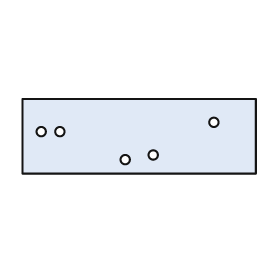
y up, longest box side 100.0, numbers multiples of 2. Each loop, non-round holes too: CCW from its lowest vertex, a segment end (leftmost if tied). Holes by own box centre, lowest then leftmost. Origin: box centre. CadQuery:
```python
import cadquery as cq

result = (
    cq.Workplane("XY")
    .moveTo(-50.0, -16.0)
    .lineTo(50.0, -16.0)
    .lineTo(50.0, 16.0)
    .lineTo(-50.0, 16.0)
    .close()
    .moveTo(-6.0, -10.0)
    .circle(2.0)
    .moveTo(6.0, -8.0)
    .circle(2.0)
    .moveTo(-42.0, 2.0)
    .circle(2.0)
    .moveTo(-34.0, 2.0)
    .circle(2.0)
    .moveTo(32.0, 6.0)
    .circle(2.0)
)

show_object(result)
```